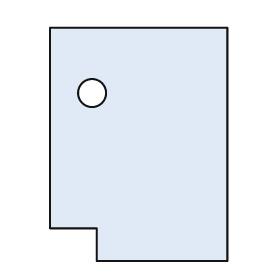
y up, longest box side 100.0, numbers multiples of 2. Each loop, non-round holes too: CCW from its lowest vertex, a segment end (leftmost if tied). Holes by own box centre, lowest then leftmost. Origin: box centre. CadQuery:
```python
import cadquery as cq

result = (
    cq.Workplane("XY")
    .moveTo(-18.0, -50.0)
    .lineTo(38.0, -50.0)
    .lineTo(38.0, 50.0)
    .lineTo(-38.0, 50.0)
    .lineTo(-38.0, -36.0)
    .lineTo(-18.0, -36.0)
    .close()
    .moveTo(-20.0, 22.0)
    .circle(6.0)
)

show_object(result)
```